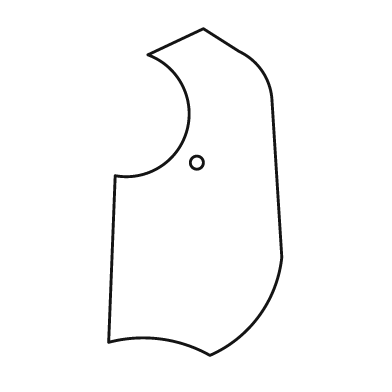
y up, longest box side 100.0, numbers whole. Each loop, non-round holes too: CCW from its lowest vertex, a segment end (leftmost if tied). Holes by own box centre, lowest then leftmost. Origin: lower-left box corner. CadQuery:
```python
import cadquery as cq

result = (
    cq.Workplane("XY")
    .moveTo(31.0, 0.0)
    .threePointArc((46.0, 12.0), (53.0, 30.0))
    .lineTo(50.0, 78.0)
    .threePointArc((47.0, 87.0), (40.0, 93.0))
    .lineTo(29.0, 100.0)
    .lineTo(12.0, 92.0)
    .threePointArc((24.0, 69.0), (2.0, 55.0))
    .lineTo(0.0, 4.0)
    .threePointArc((16.0, 5.0), (31.0, 0.0))
    .close()
    .moveTo(27.0, 59.0)
    .circle(2.0)
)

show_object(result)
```